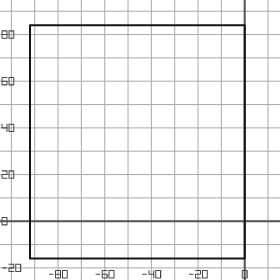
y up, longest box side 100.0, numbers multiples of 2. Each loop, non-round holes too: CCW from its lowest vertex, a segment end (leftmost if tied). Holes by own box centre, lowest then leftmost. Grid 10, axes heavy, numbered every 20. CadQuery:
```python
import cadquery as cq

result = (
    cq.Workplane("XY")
    .moveTo(-92.0, -16.0)
    .lineTo(0.0, -16.0)
    .lineTo(0.0, 84.0)
    .lineTo(-92.0, 84.0)
    .close()
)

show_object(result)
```